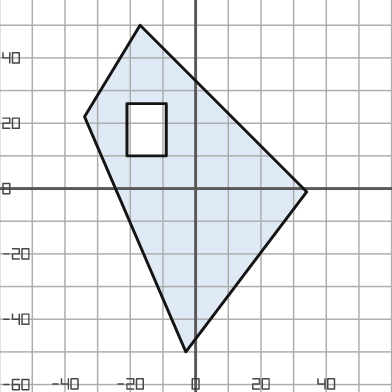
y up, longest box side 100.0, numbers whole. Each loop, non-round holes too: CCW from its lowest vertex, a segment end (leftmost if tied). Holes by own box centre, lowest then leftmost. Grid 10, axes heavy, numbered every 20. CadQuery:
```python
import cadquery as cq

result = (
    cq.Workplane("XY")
    .moveTo(-3.0, -50.0)
    .lineTo(34.0, -1.0)
    .lineTo(-17.0, 50.0)
    .lineTo(-34.0, 22.0)
    .close()
    .moveTo(-21.0, 10.0)
    .lineTo(-9.0, 10.0)
    .lineTo(-9.0, 26.0)
    .lineTo(-21.0, 26.0)
    .close()
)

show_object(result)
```